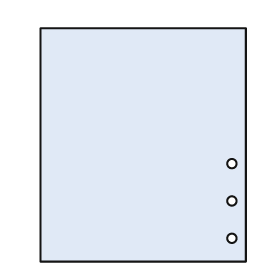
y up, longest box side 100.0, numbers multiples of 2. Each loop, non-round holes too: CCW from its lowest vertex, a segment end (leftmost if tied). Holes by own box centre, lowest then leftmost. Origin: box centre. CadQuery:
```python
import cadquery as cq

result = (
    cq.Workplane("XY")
    .moveTo(-44.0, -50.0)
    .lineTo(44.0, -50.0)
    .lineTo(44.0, 50.0)
    .lineTo(-44.0, 50.0)
    .close()
    .moveTo(38.0, -40.0)
    .circle(2.0)
    .moveTo(38.0, -24.0)
    .circle(2.0)
    .moveTo(38.0, -8.0)
    .circle(2.0)
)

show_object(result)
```